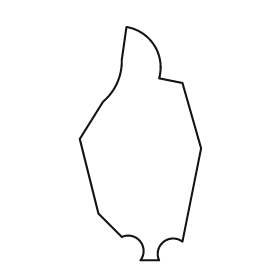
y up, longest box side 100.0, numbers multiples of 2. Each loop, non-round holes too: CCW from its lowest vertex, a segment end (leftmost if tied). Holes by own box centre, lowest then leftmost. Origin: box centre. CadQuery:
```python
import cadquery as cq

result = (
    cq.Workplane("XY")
    .moveTo(0.0, -50.0)
    .lineTo(8.0, -50.0)
    .threePointArc((10.0, -42.0), (18.0, -42.0))
    .lineTo(26.0, -2.0)
    .lineTo(18.0, 26.0)
    .lineTo(8.0, 28.0)
    .threePointArc((6.0, 42.0), (-6.0, 50.0))
    .lineTo(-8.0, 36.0)
    .threePointArc((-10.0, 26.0), (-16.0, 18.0))
    .lineTo(-26.0, 2.0)
    .lineTo(-18.0, -30.0)
    .lineTo(-8.0, -40.0)
    .threePointArc((0.0, -42.0), (0.0, -50.0))
    .close()
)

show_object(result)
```